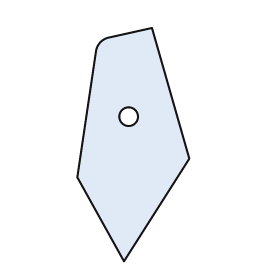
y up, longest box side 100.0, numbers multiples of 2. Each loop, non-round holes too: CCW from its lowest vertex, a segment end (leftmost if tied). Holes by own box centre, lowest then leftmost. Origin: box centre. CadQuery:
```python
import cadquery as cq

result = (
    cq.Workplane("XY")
    .moveTo(-4.0, -50.0)
    .lineTo(24.0, -6.0)
    .lineTo(8.0, 50.0)
    .lineTo(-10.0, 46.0)
    .threePointArc((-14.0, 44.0), (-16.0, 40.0))
    .lineTo(-24.0, -14.0)
    .close()
    .moveTo(-2.0, 12.0)
    .circle(4.0)
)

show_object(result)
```